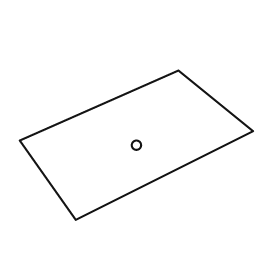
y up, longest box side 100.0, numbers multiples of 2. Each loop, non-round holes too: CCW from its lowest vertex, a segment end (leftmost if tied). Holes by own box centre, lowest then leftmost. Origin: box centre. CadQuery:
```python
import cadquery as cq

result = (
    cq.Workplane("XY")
    .moveTo(-26.0, -32.0)
    .lineTo(50.0, 6.0)
    .lineTo(18.0, 32.0)
    .lineTo(-50.0, 2.0)
    .close()
    .moveTo(0.0, 0.0)
    .circle(2.0)
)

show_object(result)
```